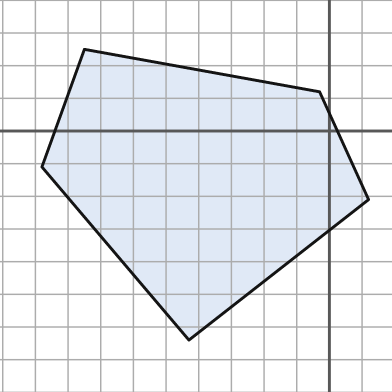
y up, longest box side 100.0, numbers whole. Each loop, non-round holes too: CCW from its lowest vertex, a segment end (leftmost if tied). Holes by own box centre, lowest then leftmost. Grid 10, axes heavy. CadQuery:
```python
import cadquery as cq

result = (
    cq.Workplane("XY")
    .moveTo(-43.0, -64.0)
    .lineTo(12.0, -21.0)
    .lineTo(-3.0, 12.0)
    .lineTo(-75.0, 25.0)
    .lineTo(-88.0, -11.0)
    .close()
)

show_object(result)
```